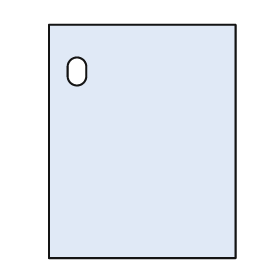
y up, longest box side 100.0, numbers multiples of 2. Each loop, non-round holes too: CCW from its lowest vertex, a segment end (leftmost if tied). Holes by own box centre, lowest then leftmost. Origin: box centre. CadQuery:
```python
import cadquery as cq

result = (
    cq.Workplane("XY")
    .moveTo(-40.0, -50.0)
    .lineTo(40.0, -50.0)
    .lineTo(40.0, 50.0)
    .lineTo(-40.0, 50.0)
    .close()
    .moveTo(-32.0, 28.0)
    .threePointArc((-28.0, 24.0), (-24.0, 28.0))
    .lineTo(-24.0, 32.0)
    .threePointArc((-28.0, 36.0), (-32.0, 32.0))
    .close()
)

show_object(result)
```